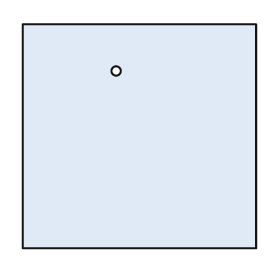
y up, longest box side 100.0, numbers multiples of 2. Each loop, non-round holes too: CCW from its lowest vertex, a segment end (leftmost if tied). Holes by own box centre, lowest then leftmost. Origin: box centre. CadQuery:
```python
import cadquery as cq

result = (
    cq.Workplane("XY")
    .moveTo(-50.0, -48.0)
    .lineTo(50.0, -48.0)
    .lineTo(50.0, 48.0)
    .lineTo(-50.0, 48.0)
    .close()
    .moveTo(-10.0, 28.0)
    .circle(2.0)
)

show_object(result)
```